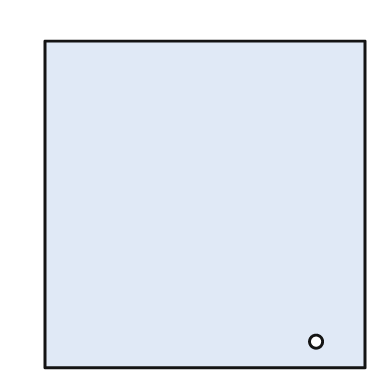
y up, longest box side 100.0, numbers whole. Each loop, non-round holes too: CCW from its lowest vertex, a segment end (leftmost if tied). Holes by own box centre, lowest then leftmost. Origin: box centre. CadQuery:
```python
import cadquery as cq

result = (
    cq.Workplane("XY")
    .moveTo(-49.0, -50.0)
    .lineTo(49.0, -50.0)
    .lineTo(49.0, 50.0)
    .lineTo(-49.0, 50.0)
    .close()
    .moveTo(34.0, -42.0)
    .circle(2.0)
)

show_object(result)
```